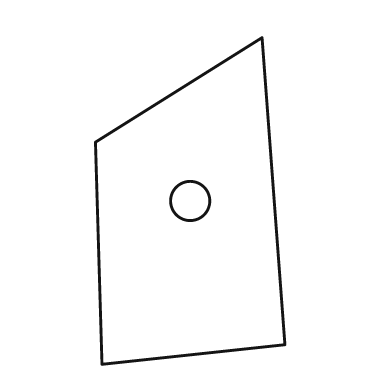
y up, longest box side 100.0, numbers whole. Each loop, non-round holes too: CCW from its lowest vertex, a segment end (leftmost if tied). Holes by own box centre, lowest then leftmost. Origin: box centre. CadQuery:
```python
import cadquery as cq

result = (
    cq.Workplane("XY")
    .moveTo(-27.0, -50.0)
    .lineTo(29.0, -44.0)
    .lineTo(22.0, 50.0)
    .lineTo(-29.0, 18.0)
    .close()
    .moveTo(0.0, 0.0)
    .circle(6.0)
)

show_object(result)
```